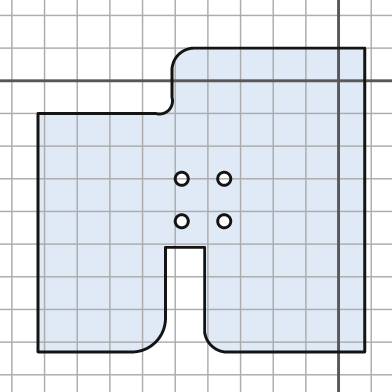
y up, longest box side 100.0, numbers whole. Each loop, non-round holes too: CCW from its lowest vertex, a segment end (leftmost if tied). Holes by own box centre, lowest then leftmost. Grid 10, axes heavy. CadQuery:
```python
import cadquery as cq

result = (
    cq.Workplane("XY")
    .moveTo(-92.0, -83.0)
    .lineTo(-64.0, -83.0)
    .threePointArc((-56.0, -80.0), (-53.0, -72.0))
    .lineTo(-53.0, -51.0)
    .lineTo(-41.0, -51.0)
    .lineTo(-41.0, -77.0)
    .threePointArc((-39.0, -81.0), (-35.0, -83.0))
    .lineTo(8.0, -83.0)
    .lineTo(8.0, 10.0)
    .lineTo(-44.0, 10.0)
    .threePointArc((-49.0, 8.0), (-51.0, 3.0))
    .lineTo(-51.0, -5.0)
    .threePointArc((-52.0, -9.0), (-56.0, -10.0))
    .lineTo(-92.0, -10.0)
    .close()
    .moveTo(-48.0, -43.0)
    .circle(2.0)
    .moveTo(-35.0, -43.0)
    .circle(2.0)
    .moveTo(-48.0, -30.0)
    .circle(2.0)
    .moveTo(-35.0, -30.0)
    .circle(2.0)
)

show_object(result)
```